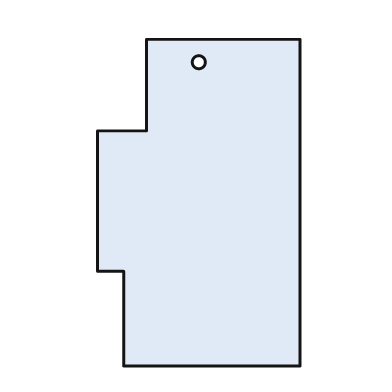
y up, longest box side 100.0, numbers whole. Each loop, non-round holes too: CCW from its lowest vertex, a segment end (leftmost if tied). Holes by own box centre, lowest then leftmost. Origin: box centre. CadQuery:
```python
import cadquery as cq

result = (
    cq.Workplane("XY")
    .moveTo(-23.0, -50.0)
    .lineTo(31.0, -50.0)
    .lineTo(31.0, 50.0)
    .lineTo(-16.0, 50.0)
    .lineTo(-16.0, 22.0)
    .lineTo(-31.0, 22.0)
    .lineTo(-31.0, -21.0)
    .lineTo(-23.0, -21.0)
    .close()
    .moveTo(0.0, 43.0)
    .circle(2.0)
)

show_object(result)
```